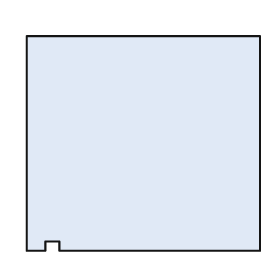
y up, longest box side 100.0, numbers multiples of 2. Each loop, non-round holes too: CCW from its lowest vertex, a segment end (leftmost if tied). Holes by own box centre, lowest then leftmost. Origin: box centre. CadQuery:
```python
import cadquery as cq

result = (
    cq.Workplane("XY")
    .moveTo(-50.0, -46.0)
    .lineTo(-42.0, -46.0)
    .lineTo(-42.0, -42.0)
    .lineTo(-36.0, -42.0)
    .lineTo(-36.0, -46.0)
    .lineTo(50.0, -46.0)
    .lineTo(50.0, 46.0)
    .lineTo(-50.0, 46.0)
    .close()
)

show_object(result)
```